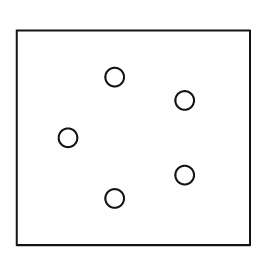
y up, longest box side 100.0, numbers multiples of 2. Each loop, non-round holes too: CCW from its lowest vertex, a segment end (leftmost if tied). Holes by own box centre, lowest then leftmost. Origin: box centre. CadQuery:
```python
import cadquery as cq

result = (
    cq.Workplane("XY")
    .moveTo(-50.0, -46.0)
    .lineTo(50.0, -46.0)
    .lineTo(50.0, 46.0)
    .lineTo(-50.0, 46.0)
    .close()
    .moveTo(-8.0, -26.0)
    .circle(4.0)
    .moveTo(22.0, -16.0)
    .circle(4.0)
    .moveTo(-28.0, 0.0)
    .circle(4.0)
    .moveTo(22.0, 16.0)
    .circle(4.0)
    .moveTo(-8.0, 26.0)
    .circle(4.0)
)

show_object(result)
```